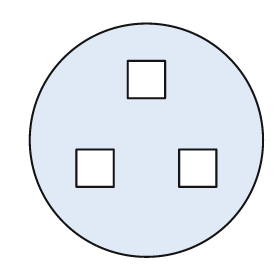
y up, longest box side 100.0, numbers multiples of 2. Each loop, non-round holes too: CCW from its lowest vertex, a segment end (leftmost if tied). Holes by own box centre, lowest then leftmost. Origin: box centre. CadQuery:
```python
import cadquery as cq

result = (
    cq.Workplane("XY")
    .moveTo(0.0, 0.0)
    .circle(50.0)
    .moveTo(-30.0, -20.0)
    .lineTo(-14.0, -20.0)
    .lineTo(-14.0, -4.0)
    .lineTo(-30.0, -4.0)
    .close()
    .moveTo(14.0, -20.0)
    .lineTo(30.0, -20.0)
    .lineTo(30.0, -4.0)
    .lineTo(14.0, -4.0)
    .close()
    .moveTo(-8.0, 18.0)
    .lineTo(8.0, 18.0)
    .lineTo(8.0, 34.0)
    .lineTo(-8.0, 34.0)
    .close()
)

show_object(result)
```